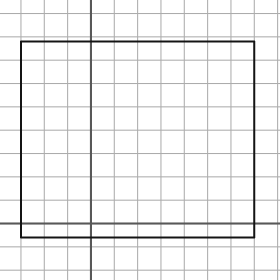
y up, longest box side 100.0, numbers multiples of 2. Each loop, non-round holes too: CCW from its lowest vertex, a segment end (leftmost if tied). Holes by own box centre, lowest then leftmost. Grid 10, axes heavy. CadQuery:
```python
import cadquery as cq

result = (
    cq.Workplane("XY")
    .moveTo(-30.0, -6.0)
    .lineTo(70.0, -6.0)
    .lineTo(70.0, 78.0)
    .lineTo(-30.0, 78.0)
    .close()
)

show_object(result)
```